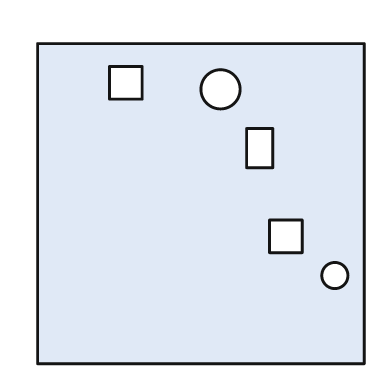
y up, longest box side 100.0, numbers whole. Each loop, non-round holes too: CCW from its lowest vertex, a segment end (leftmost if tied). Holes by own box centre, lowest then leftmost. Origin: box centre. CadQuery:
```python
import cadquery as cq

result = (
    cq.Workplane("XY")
    .moveTo(-50.0, -49.0)
    .lineTo(50.0, -49.0)
    .lineTo(50.0, 49.0)
    .lineTo(-50.0, 49.0)
    .close()
    .moveTo(41.0, -22.0)
    .circle(4.0)
    .moveTo(21.0, -15.0)
    .lineTo(31.0, -15.0)
    .lineTo(31.0, -5.0)
    .lineTo(21.0, -5.0)
    .close()
    .moveTo(14.0, 11.0)
    .lineTo(22.0, 11.0)
    .lineTo(22.0, 23.0)
    .lineTo(14.0, 23.0)
    .close()
    .moveTo(6.0, 35.0)
    .circle(6.0)
    .moveTo(-28.0, 32.0)
    .lineTo(-18.0, 32.0)
    .lineTo(-18.0, 42.0)
    .lineTo(-28.0, 42.0)
    .close()
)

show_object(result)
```